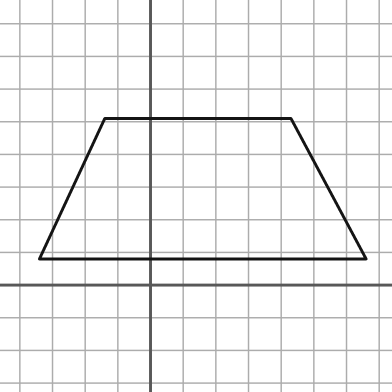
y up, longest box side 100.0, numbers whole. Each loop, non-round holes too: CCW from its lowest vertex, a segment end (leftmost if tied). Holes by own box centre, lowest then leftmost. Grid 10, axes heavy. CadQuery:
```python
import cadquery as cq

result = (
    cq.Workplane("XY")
    .moveTo(-34.0, 8.0)
    .lineTo(66.0, 8.0)
    .lineTo(43.0, 51.0)
    .lineTo(-14.0, 51.0)
    .close()
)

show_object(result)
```